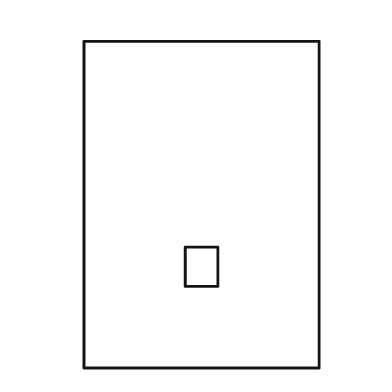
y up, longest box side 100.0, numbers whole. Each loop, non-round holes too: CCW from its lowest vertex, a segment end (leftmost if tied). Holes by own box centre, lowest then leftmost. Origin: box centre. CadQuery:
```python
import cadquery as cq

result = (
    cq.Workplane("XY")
    .moveTo(-36.0, -50.0)
    .lineTo(36.0, -50.0)
    .lineTo(36.0, 50.0)
    .lineTo(-36.0, 50.0)
    .close()
    .moveTo(-5.0, -25.0)
    .lineTo(5.0, -25.0)
    .lineTo(5.0, -13.0)
    .lineTo(-5.0, -13.0)
    .close()
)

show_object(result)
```